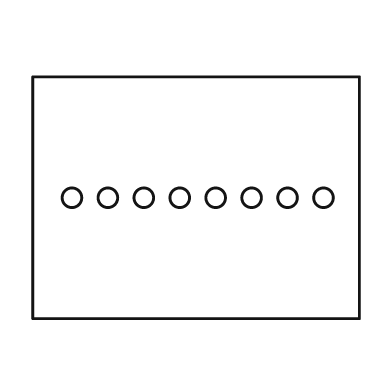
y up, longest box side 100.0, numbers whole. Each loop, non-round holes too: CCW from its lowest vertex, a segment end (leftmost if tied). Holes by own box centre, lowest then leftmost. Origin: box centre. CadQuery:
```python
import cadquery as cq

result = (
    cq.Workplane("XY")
    .moveTo(-50.0, -37.0)
    .lineTo(50.0, -37.0)
    .lineTo(50.0, 37.0)
    .lineTo(-50.0, 37.0)
    .close()
    .moveTo(-38.0, 0.0)
    .circle(3.0)
    .moveTo(-27.0, 0.0)
    .circle(3.0)
    .moveTo(-16.0, 0.0)
    .circle(3.0)
    .moveTo(-5.0, 0.0)
    .circle(3.0)
    .moveTo(6.0, 0.0)
    .circle(3.0)
    .moveTo(17.0, 0.0)
    .circle(3.0)
    .moveTo(28.0, 0.0)
    .circle(3.0)
    .moveTo(39.0, 0.0)
    .circle(3.0)
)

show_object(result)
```